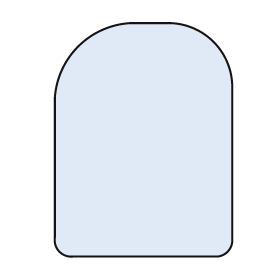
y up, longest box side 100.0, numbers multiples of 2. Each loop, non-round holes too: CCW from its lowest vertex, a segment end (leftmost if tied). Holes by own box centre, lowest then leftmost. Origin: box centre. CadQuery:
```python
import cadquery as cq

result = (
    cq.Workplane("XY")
    .moveTo(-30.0, -50.0)
    .lineTo(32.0, -50.0)
    .threePointArc((36.0, -48.0), (38.0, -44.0))
    .lineTo(38.0, 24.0)
    .threePointArc((30.0, 42.0), (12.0, 50.0))
    .lineTo(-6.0, 50.0)
    .threePointArc((-28.0, 40.0), (-38.0, 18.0))
    .lineTo(-38.0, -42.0)
    .threePointArc((-36.0, -48.0), (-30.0, -50.0))
    .close()
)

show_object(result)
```